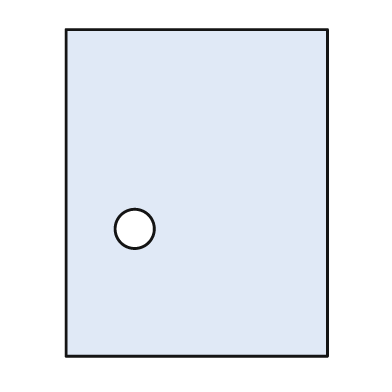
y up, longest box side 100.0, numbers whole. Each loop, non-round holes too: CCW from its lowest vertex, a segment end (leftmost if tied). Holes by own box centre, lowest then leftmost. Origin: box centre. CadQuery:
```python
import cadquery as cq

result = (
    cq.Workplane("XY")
    .moveTo(-40.0, -50.0)
    .lineTo(40.0, -50.0)
    .lineTo(40.0, 50.0)
    .lineTo(-40.0, 50.0)
    .close()
    .moveTo(-19.0, -11.0)
    .circle(6.0)
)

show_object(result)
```